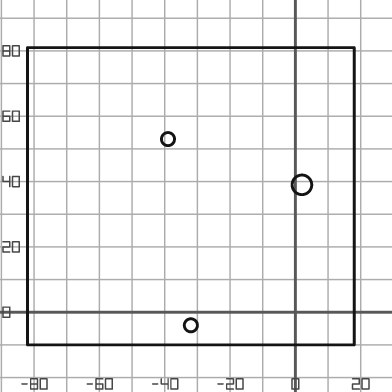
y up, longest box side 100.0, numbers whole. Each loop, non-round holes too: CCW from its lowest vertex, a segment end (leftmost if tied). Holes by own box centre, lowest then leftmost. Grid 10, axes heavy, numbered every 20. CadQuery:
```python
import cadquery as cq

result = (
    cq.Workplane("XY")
    .moveTo(-82.0, -10.0)
    .lineTo(18.0, -10.0)
    .lineTo(18.0, 81.0)
    .lineTo(-82.0, 81.0)
    .close()
    .moveTo(-32.0, -4.0)
    .circle(2.0)
    .moveTo(2.0, 39.0)
    .circle(3.0)
    .moveTo(-39.0, 53.0)
    .circle(2.0)
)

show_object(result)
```